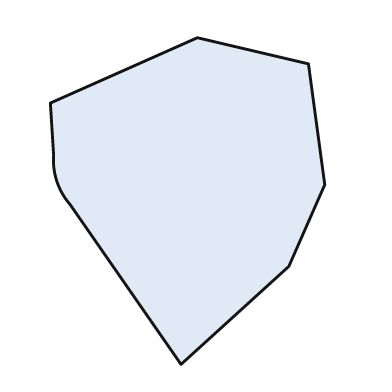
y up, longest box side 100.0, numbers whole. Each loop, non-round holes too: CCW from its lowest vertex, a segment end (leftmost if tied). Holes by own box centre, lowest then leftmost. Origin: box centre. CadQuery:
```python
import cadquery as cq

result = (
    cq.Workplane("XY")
    .moveTo(-2.0, -50.0)
    .lineTo(31.0, -20.0)
    .lineTo(42.0, 5.0)
    .lineTo(37.0, 42.0)
    .lineTo(3.0, 50.0)
    .lineTo(-42.0, 30.0)
    .lineTo(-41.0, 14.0)
    .threePointArc((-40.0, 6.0), (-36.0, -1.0))
    .close()
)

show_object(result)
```